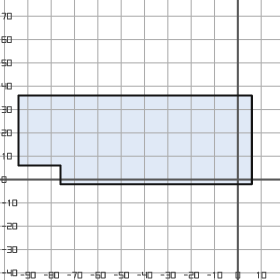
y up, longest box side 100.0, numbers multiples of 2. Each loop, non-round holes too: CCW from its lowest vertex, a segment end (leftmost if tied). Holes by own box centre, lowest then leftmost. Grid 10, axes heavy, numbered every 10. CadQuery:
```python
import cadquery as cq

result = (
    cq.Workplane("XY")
    .moveTo(-76.0, -2.0)
    .lineTo(6.0, -2.0)
    .lineTo(6.0, 36.0)
    .lineTo(-94.0, 36.0)
    .lineTo(-94.0, 6.0)
    .lineTo(-76.0, 6.0)
    .close()
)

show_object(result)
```